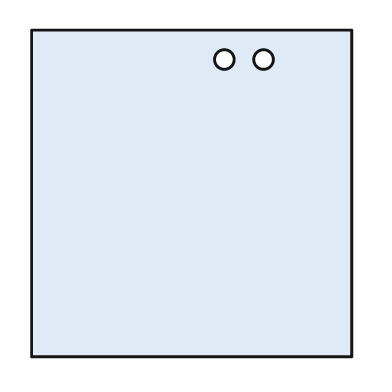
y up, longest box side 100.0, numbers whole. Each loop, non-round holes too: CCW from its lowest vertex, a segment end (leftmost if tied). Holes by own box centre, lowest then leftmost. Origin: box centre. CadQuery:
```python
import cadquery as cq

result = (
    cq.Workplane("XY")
    .moveTo(-49.0, -50.0)
    .lineTo(49.0, -50.0)
    .lineTo(49.0, 50.0)
    .lineTo(-49.0, 50.0)
    .close()
    .moveTo(10.0, 41.0)
    .circle(3.0)
    .moveTo(22.0, 41.0)
    .circle(3.0)
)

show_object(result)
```